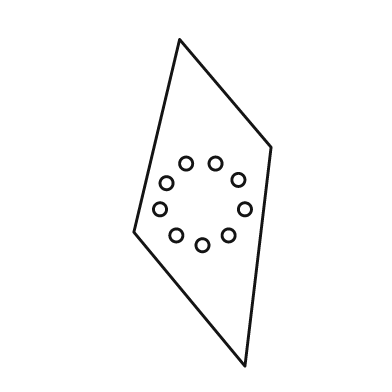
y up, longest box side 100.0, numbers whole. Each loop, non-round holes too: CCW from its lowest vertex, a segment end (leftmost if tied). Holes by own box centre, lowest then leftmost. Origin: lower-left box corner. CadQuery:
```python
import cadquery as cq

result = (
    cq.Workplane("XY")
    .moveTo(34.0, 0.0)
    .lineTo(42.0, 67.0)
    .lineTo(14.0, 100.0)
    .lineTo(0.0, 41.0)
    .close()
    .moveTo(21.0, 37.0)
    .circle(2.0)
    .moveTo(13.0, 40.0)
    .circle(2.0)
    .moveTo(29.0, 40.0)
    .circle(2.0)
    .moveTo(8.0, 48.0)
    .circle(2.0)
    .moveTo(34.0, 48.0)
    .circle(2.0)
    .moveTo(10.0, 56.0)
    .circle(2.0)
    .moveTo(32.0, 57.0)
    .circle(2.0)
    .moveTo(16.0, 62.0)
    .circle(2.0)
    .moveTo(25.0, 62.0)
    .circle(2.0)
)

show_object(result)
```